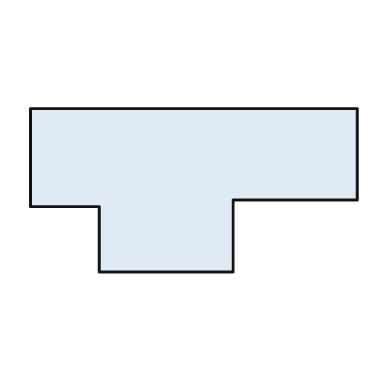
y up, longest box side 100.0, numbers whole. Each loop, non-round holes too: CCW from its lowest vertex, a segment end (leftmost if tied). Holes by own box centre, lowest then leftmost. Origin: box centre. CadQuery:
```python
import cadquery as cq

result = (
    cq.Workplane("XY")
    .moveTo(-29.0, -25.0)
    .lineTo(12.0, -25.0)
    .lineTo(12.0, -3.0)
    .lineTo(50.0, -3.0)
    .lineTo(50.0, 25.0)
    .lineTo(-50.0, 25.0)
    .lineTo(-50.0, -5.0)
    .lineTo(-29.0, -5.0)
    .close()
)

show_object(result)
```